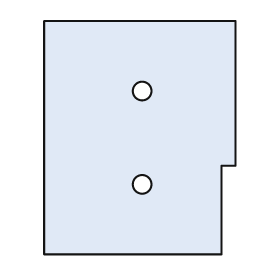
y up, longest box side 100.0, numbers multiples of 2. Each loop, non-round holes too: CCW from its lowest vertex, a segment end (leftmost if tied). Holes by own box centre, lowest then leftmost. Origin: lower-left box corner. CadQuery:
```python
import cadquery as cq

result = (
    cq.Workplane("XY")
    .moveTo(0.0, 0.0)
    .lineTo(76.0, 0.0)
    .lineTo(76.0, 38.0)
    .lineTo(82.0, 38.0)
    .lineTo(82.0, 100.0)
    .lineTo(0.0, 100.0)
    .close()
    .moveTo(42.0, 30.0)
    .circle(4.0)
    .moveTo(42.0, 70.0)
    .circle(4.0)
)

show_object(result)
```